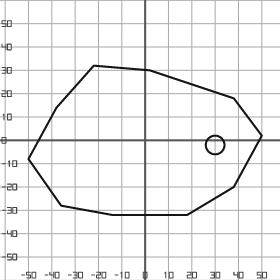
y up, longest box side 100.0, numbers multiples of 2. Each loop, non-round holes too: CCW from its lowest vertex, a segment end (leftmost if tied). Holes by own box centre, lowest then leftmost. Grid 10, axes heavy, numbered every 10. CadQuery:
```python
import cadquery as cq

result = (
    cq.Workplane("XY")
    .moveTo(-14.0, -32.0)
    .lineTo(18.0, -32.0)
    .lineTo(38.0, -20.0)
    .lineTo(50.0, 2.0)
    .lineTo(38.0, 18.0)
    .lineTo(2.0, 30.0)
    .lineTo(-22.0, 32.0)
    .lineTo(-38.0, 14.0)
    .lineTo(-50.0, -8.0)
    .lineTo(-36.0, -28.0)
    .close()
    .moveTo(30.0, -2.0)
    .circle(4.0)
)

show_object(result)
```